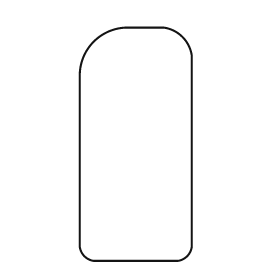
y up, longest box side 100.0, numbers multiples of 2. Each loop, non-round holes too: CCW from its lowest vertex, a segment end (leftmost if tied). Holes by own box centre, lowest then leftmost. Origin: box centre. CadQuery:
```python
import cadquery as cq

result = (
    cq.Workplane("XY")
    .moveTo(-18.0, -50.0)
    .lineTo(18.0, -50.0)
    .threePointArc((22.0, -48.0), (24.0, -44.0))
    .lineTo(24.0, 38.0)
    .threePointArc((20.0, 46.0), (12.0, 50.0))
    .lineTo(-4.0, 50.0)
    .threePointArc((-18.0, 44.0), (-24.0, 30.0))
    .lineTo(-24.0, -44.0)
    .threePointArc((-22.0, -48.0), (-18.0, -50.0))
    .close()
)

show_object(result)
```